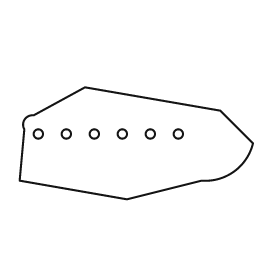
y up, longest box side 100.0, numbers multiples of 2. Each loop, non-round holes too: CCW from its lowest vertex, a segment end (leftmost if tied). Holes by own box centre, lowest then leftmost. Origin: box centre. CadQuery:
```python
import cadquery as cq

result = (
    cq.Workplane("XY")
    .moveTo(-4.0, -24.0)
    .lineTo(28.0, -16.0)
    .threePointArc((42.0, -12.0), (50.0, 0.0))
    .lineTo(36.0, 14.0)
    .lineTo(-22.0, 24.0)
    .lineTo(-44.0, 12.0)
    .threePointArc((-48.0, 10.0), (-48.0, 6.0))
    .lineTo(-50.0, -16.0)
    .close()
    .moveTo(-42.0, 4.0)
    .circle(2.0)
    .moveTo(-30.0, 4.0)
    .circle(2.0)
    .moveTo(-18.0, 4.0)
    .circle(2.0)
    .moveTo(-6.0, 4.0)
    .circle(2.0)
    .moveTo(6.0, 4.0)
    .circle(2.0)
    .moveTo(18.0, 4.0)
    .circle(2.0)
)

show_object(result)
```